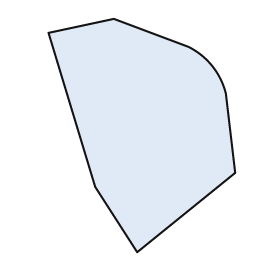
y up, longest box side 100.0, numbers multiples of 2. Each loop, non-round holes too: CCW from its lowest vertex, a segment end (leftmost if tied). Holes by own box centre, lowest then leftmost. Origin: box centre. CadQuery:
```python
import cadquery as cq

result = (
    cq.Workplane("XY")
    .moveTo(-2.0, -50.0)
    .lineTo(40.0, -16.0)
    .lineTo(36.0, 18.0)
    .threePointArc((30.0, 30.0), (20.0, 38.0))
    .lineTo(-12.0, 50.0)
    .lineTo(-40.0, 44.0)
    .lineTo(-20.0, -22.0)
    .close()
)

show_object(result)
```